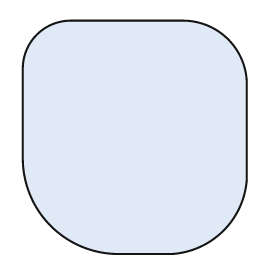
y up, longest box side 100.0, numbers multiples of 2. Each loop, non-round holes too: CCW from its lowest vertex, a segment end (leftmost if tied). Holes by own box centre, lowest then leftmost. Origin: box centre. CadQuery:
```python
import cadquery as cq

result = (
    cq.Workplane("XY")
    .moveTo(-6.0, -50.0)
    .lineTo(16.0, -50.0)
    .threePointArc((38.0, -40.0), (48.0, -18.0))
    .lineTo(48.0, 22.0)
    .threePointArc((40.0, 42.0), (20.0, 50.0))
    .lineTo(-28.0, 50.0)
    .threePointArc((-42.0, 44.0), (-48.0, 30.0))
    .lineTo(-48.0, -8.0)
    .threePointArc((-36.0, -38.0), (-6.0, -50.0))
    .close()
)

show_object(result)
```